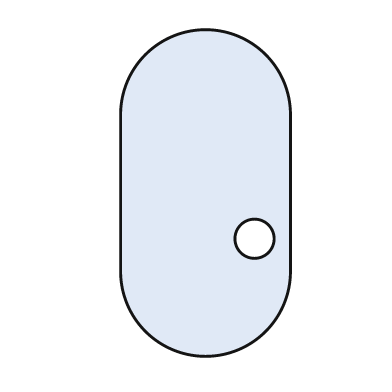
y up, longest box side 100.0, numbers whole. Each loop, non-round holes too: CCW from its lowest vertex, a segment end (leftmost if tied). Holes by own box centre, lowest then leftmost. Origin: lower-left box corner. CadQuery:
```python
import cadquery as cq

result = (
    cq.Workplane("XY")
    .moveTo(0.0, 26.0)
    .threePointArc((26.0, 0.0), (52.0, 26.0))
    .lineTo(52.0, 74.0)
    .threePointArc((26.0, 100.0), (0.0, 74.0))
    .close()
    .moveTo(41.0, 36.0)
    .circle(6.0)
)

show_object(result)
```